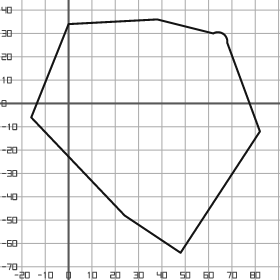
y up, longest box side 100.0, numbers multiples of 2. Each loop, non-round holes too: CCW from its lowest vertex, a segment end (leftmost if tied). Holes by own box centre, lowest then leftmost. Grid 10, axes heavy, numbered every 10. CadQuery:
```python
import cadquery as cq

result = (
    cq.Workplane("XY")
    .moveTo(48.0, -64.0)
    .lineTo(82.0, -12.0)
    .lineTo(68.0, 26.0)
    .threePointArc((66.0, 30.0), (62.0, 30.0))
    .lineTo(38.0, 36.0)
    .lineTo(0.0, 34.0)
    .lineTo(-16.0, -6.0)
    .lineTo(24.0, -48.0)
    .close()
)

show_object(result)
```